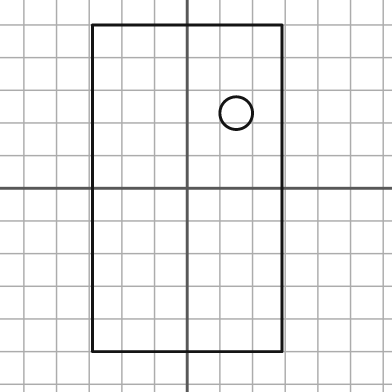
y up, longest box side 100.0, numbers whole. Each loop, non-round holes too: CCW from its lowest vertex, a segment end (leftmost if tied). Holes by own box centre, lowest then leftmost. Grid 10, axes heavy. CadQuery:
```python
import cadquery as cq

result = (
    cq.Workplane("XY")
    .moveTo(-29.0, -50.0)
    .lineTo(29.0, -50.0)
    .lineTo(29.0, 50.0)
    .lineTo(-29.0, 50.0)
    .close()
    .moveTo(15.0, 23.0)
    .circle(5.0)
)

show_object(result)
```